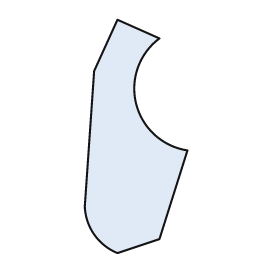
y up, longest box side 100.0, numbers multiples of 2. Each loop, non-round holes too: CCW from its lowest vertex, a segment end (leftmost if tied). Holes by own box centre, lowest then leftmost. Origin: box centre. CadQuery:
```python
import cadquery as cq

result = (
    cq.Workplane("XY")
    .moveTo(-8.0, -50.0)
    .lineTo(10.0, -44.0)
    .lineTo(22.0, -6.0)
    .threePointArc((0.0, 14.0), (10.0, 42.0))
    .lineTo(-8.0, 50.0)
    .lineTo(-18.0, 28.0)
    .lineTo(-22.0, -30.0)
    .threePointArc((-18.0, -42.0), (-8.0, -50.0))
    .close()
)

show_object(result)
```